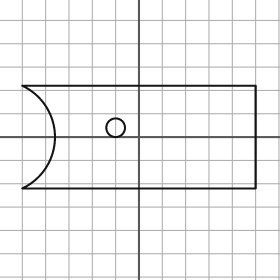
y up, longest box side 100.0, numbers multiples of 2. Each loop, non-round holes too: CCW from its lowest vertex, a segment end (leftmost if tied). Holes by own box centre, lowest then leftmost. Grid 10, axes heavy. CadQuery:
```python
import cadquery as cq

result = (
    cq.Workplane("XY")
    .moveTo(-50.0, -22.0)
    .lineTo(50.0, -22.0)
    .lineTo(50.0, 22.0)
    .lineTo(-50.0, 22.0)
    .threePointArc((-36.0, 0.0), (-50.0, -22.0))
    .close()
    .moveTo(-10.0, 4.0)
    .circle(4.0)
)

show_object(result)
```